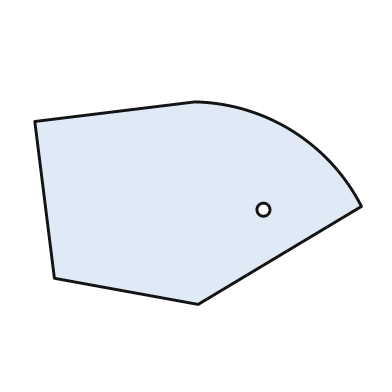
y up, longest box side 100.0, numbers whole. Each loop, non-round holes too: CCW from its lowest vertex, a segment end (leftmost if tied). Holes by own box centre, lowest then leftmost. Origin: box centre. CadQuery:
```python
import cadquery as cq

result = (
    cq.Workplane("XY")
    .moveTo(0.0, -31.0)
    .lineTo(50.0, -1.0)
    .threePointArc((29.0, 22.0), (-1.0, 31.0))
    .lineTo(-50.0, 25.0)
    .lineTo(-44.0, -23.0)
    .close()
    .moveTo(20.0, -2.0)
    .circle(2.0)
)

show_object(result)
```